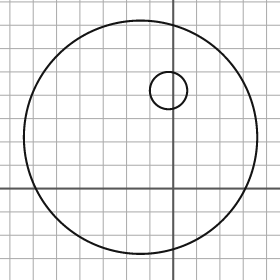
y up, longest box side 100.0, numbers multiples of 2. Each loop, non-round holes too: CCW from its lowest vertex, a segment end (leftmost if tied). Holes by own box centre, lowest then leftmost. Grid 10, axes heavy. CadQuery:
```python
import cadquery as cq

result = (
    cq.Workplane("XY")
    .moveTo(-14.0, 22.0)
    .circle(50.0)
    .moveTo(-2.0, 42.0)
    .circle(8.0)
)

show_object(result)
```